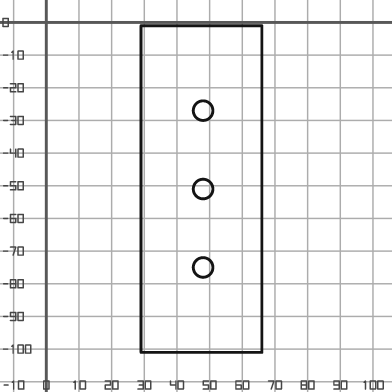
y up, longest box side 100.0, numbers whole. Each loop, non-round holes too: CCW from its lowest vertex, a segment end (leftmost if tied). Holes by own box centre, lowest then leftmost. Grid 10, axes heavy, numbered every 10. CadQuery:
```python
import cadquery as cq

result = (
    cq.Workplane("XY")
    .moveTo(29.0, -101.0)
    .lineTo(66.0, -101.0)
    .lineTo(66.0, -1.0)
    .lineTo(29.0, -1.0)
    .close()
    .moveTo(48.0, -75.0)
    .circle(3.0)
    .moveTo(48.0, -51.0)
    .circle(3.0)
    .moveTo(48.0, -27.0)
    .circle(3.0)
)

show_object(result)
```